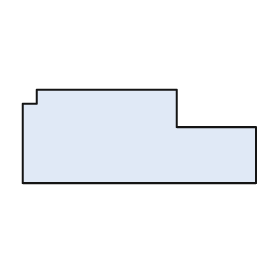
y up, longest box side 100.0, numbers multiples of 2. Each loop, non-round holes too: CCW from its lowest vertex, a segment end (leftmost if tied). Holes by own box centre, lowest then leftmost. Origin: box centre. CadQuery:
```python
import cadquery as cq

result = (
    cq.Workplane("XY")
    .moveTo(-50.0, -20.0)
    .lineTo(50.0, -20.0)
    .lineTo(50.0, 4.0)
    .lineTo(16.0, 4.0)
    .lineTo(16.0, 20.0)
    .lineTo(-44.0, 20.0)
    .lineTo(-44.0, 14.0)
    .lineTo(-50.0, 14.0)
    .close()
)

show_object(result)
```